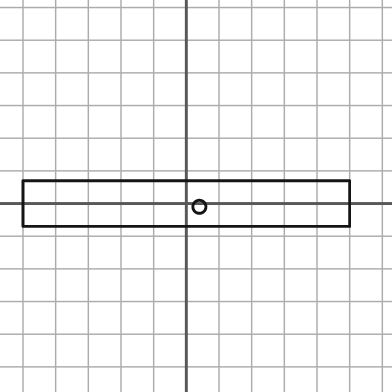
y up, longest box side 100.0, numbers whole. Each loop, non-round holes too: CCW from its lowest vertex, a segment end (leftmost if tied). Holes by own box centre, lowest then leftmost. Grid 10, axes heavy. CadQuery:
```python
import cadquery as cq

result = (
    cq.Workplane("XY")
    .moveTo(-50.0, -7.0)
    .lineTo(50.0, -7.0)
    .lineTo(50.0, 7.0)
    .lineTo(-50.0, 7.0)
    .close()
    .moveTo(4.0, -1.0)
    .circle(2.0)
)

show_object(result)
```